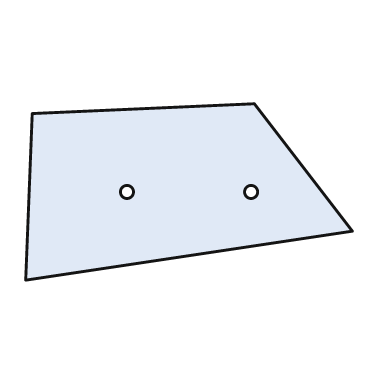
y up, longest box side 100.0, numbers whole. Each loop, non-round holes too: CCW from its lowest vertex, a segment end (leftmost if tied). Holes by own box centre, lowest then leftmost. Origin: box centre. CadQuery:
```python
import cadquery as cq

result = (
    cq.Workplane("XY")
    .moveTo(-50.0, -27.0)
    .lineTo(50.0, -12.0)
    .lineTo(20.0, 27.0)
    .lineTo(-48.0, 24.0)
    .close()
    .moveTo(-19.0, 0.0)
    .circle(2.0)
    .moveTo(19.0, 0.0)
    .circle(2.0)
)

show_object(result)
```